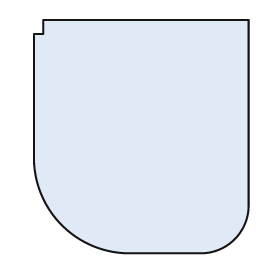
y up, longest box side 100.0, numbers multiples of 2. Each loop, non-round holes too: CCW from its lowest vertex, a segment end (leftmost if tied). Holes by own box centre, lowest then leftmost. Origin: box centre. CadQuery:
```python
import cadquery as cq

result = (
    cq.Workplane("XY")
    .moveTo(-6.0, -50.0)
    .lineTo(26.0, -50.0)
    .threePointArc((40.0, -44.0), (46.0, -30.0))
    .lineTo(46.0, 50.0)
    .lineTo(-42.0, 50.0)
    .lineTo(-42.0, 44.0)
    .lineTo(-46.0, 44.0)
    .lineTo(-46.0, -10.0)
    .threePointArc((-34.0, -38.0), (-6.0, -50.0))
    .close()
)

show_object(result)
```